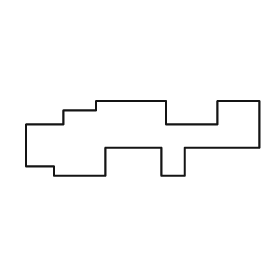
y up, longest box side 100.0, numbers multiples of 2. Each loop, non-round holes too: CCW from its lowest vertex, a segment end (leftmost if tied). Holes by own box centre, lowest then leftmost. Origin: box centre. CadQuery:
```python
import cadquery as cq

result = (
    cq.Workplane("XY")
    .moveTo(-38.0, -16.0)
    .lineTo(-16.0, -16.0)
    .lineTo(-16.0, -4.0)
    .lineTo(8.0, -4.0)
    .lineTo(8.0, -16.0)
    .lineTo(18.0, -16.0)
    .lineTo(18.0, -4.0)
    .lineTo(50.0, -4.0)
    .lineTo(50.0, 16.0)
    .lineTo(32.0, 16.0)
    .lineTo(32.0, 6.0)
    .lineTo(10.0, 6.0)
    .lineTo(10.0, 16.0)
    .lineTo(-20.0, 16.0)
    .lineTo(-20.0, 12.0)
    .lineTo(-34.0, 12.0)
    .lineTo(-34.0, 6.0)
    .lineTo(-50.0, 6.0)
    .lineTo(-50.0, -12.0)
    .lineTo(-38.0, -12.0)
    .close()
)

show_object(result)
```